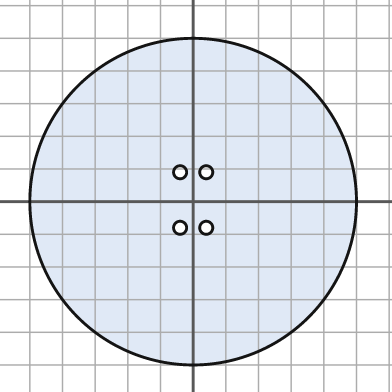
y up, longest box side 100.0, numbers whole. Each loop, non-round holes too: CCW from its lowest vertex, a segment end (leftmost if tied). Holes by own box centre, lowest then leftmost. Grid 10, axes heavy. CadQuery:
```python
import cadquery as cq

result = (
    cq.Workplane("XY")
    .moveTo(0.0, 0.0)
    .circle(50.0)
    .moveTo(-4.0, -8.0)
    .circle(2.0)
    .moveTo(4.0, -8.0)
    .circle(2.0)
    .moveTo(-4.0, 9.0)
    .circle(2.0)
    .moveTo(4.0, 9.0)
    .circle(2.0)
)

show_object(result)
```